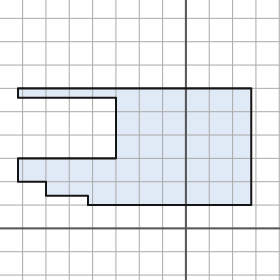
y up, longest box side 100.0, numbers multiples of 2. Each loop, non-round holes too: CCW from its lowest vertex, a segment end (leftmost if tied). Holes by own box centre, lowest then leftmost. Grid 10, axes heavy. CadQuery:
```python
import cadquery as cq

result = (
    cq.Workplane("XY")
    .moveTo(-42.0, 10.0)
    .lineTo(28.0, 10.0)
    .lineTo(28.0, 60.0)
    .lineTo(-72.0, 60.0)
    .lineTo(-72.0, 56.0)
    .lineTo(-30.0, 56.0)
    .lineTo(-30.0, 30.0)
    .lineTo(-72.0, 30.0)
    .lineTo(-72.0, 20.0)
    .lineTo(-60.0, 20.0)
    .lineTo(-60.0, 14.0)
    .lineTo(-42.0, 14.0)
    .close()
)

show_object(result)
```